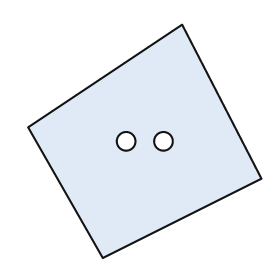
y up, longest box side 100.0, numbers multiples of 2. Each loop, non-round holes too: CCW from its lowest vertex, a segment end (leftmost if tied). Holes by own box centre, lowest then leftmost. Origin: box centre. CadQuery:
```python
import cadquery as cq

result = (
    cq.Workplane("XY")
    .moveTo(-18.0, -50.0)
    .lineTo(50.0, -16.0)
    .lineTo(16.0, 50.0)
    .lineTo(-50.0, 6.0)
    .close()
    .moveTo(-8.0, 0.0)
    .circle(4.0)
    .moveTo(8.0, 0.0)
    .circle(4.0)
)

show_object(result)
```